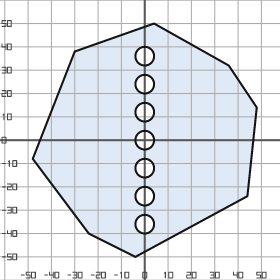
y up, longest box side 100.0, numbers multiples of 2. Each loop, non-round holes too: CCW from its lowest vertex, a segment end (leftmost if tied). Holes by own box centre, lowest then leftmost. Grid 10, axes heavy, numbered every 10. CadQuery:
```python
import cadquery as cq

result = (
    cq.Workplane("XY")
    .moveTo(-4.0, -50.0)
    .lineTo(44.0, -24.0)
    .lineTo(48.0, 14.0)
    .lineTo(36.0, 32.0)
    .lineTo(4.0, 50.0)
    .lineTo(-30.0, 38.0)
    .lineTo(-48.0, -8.0)
    .lineTo(-24.0, -40.0)
    .close()
    .moveTo(0.0, -36.0)
    .circle(4.0)
    .moveTo(0.0, -24.0)
    .circle(4.0)
    .moveTo(0.0, -12.0)
    .circle(4.0)
    .moveTo(0.0, 0.0)
    .circle(4.0)
    .moveTo(0.0, 12.0)
    .circle(4.0)
    .moveTo(0.0, 24.0)
    .circle(4.0)
    .moveTo(0.0, 36.0)
    .circle(4.0)
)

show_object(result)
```